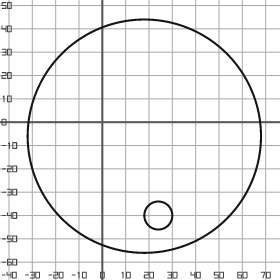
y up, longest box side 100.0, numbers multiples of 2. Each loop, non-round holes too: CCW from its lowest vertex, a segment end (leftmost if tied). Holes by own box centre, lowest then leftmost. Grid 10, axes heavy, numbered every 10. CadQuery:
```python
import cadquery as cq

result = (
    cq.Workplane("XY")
    .moveTo(18.0, -6.0)
    .circle(50.0)
    .moveTo(24.0, -40.0)
    .circle(6.0)
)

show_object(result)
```